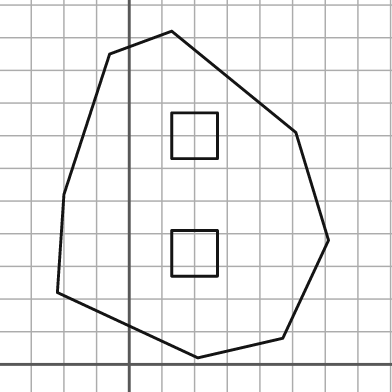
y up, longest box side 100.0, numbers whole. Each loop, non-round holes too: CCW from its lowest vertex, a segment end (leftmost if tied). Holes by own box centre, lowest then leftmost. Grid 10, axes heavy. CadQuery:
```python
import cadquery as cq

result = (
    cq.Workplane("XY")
    .moveTo(21.0, 2.0)
    .lineTo(47.0, 8.0)
    .lineTo(61.0, 38.0)
    .lineTo(51.0, 71.0)
    .lineTo(13.0, 102.0)
    .lineTo(-6.0, 95.0)
    .lineTo(-20.0, 52.0)
    .lineTo(-22.0, 22.0)
    .close()
    .moveTo(13.0, 27.0)
    .lineTo(27.0, 27.0)
    .lineTo(27.0, 41.0)
    .lineTo(13.0, 41.0)
    .close()
    .moveTo(13.0, 63.0)
    .lineTo(27.0, 63.0)
    .lineTo(27.0, 77.0)
    .lineTo(13.0, 77.0)
    .close()
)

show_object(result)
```